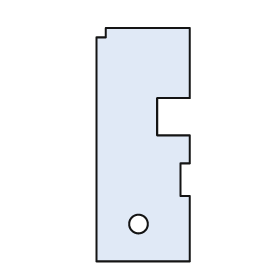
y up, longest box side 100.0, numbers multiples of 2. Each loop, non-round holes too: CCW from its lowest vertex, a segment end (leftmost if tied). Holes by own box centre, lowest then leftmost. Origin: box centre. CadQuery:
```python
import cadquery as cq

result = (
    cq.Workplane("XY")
    .moveTo(-20.0, -50.0)
    .lineTo(20.0, -50.0)
    .lineTo(20.0, -22.0)
    .lineTo(16.0, -22.0)
    .lineTo(16.0, -8.0)
    .lineTo(20.0, -8.0)
    .lineTo(20.0, 4.0)
    .lineTo(6.0, 4.0)
    .lineTo(6.0, 20.0)
    .lineTo(20.0, 20.0)
    .lineTo(20.0, 50.0)
    .lineTo(-16.0, 50.0)
    .lineTo(-16.0, 46.0)
    .lineTo(-20.0, 46.0)
    .close()
    .moveTo(-2.0, -34.0)
    .circle(4.0)
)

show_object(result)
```